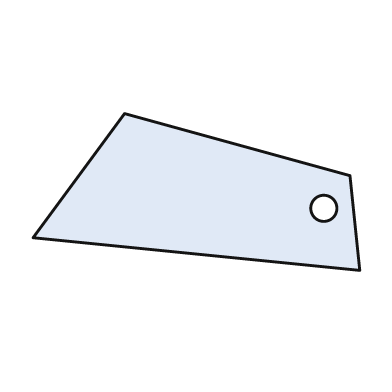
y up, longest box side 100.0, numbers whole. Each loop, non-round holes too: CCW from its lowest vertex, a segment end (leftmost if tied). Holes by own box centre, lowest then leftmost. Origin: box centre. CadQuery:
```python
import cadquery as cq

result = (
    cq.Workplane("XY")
    .moveTo(50.0, -24.0)
    .lineTo(47.0, 5.0)
    .lineTo(-22.0, 24.0)
    .lineTo(-50.0, -14.0)
    .close()
    .moveTo(39.0, -5.0)
    .circle(4.0)
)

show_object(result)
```